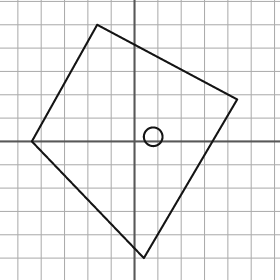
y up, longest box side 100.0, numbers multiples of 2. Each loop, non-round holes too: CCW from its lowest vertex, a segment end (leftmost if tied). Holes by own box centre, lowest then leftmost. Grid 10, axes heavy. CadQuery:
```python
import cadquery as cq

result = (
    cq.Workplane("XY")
    .moveTo(4.0, -50.0)
    .lineTo(44.0, 18.0)
    .lineTo(-16.0, 50.0)
    .lineTo(-44.0, 0.0)
    .close()
    .moveTo(8.0, 2.0)
    .circle(4.0)
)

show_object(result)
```